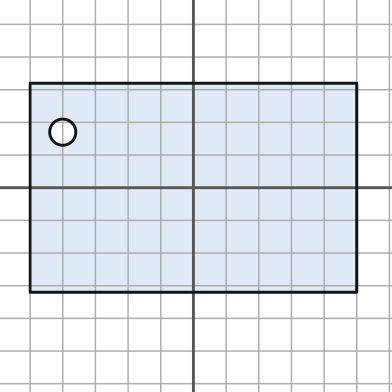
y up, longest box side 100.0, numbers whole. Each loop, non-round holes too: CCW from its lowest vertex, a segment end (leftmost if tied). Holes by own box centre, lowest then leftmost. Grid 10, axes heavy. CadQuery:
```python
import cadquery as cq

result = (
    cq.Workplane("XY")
    .moveTo(-50.0, -32.0)
    .lineTo(50.0, -32.0)
    .lineTo(50.0, 32.0)
    .lineTo(-50.0, 32.0)
    .close()
    .moveTo(-40.0, 17.0)
    .circle(4.0)
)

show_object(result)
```